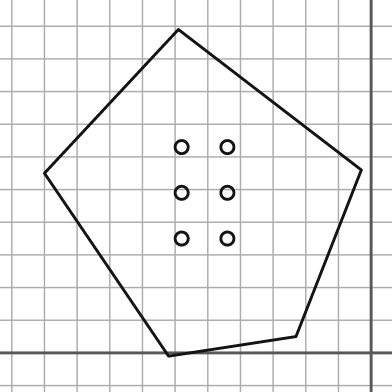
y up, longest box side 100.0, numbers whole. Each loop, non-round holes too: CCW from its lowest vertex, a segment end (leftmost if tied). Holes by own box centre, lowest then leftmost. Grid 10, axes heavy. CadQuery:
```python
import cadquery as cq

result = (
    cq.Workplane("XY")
    .moveTo(-62.0, -1.0)
    .lineTo(-23.0, 5.0)
    .lineTo(-3.0, 56.0)
    .lineTo(-59.0, 99.0)
    .lineTo(-100.0, 55.0)
    .close()
    .moveTo(-58.0, 35.0)
    .circle(2.0)
    .moveTo(-44.0, 35.0)
    .circle(2.0)
    .moveTo(-58.0, 49.0)
    .circle(2.0)
    .moveTo(-44.0, 49.0)
    .circle(2.0)
    .moveTo(-58.0, 63.0)
    .circle(2.0)
    .moveTo(-44.0, 63.0)
    .circle(2.0)
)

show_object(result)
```